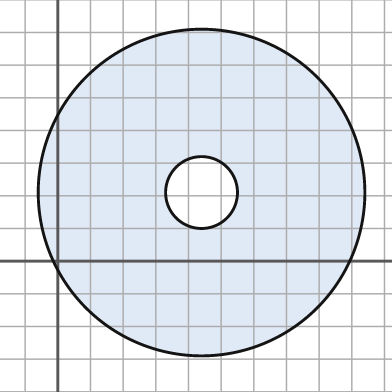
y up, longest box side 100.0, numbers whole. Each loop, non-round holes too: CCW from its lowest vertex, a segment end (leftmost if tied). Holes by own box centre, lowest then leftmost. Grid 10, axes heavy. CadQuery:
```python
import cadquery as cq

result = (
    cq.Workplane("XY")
    .moveTo(44.0, 21.0)
    .circle(50.0)
    .moveTo(44.0, 21.0)
    .circle(11.0)
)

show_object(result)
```